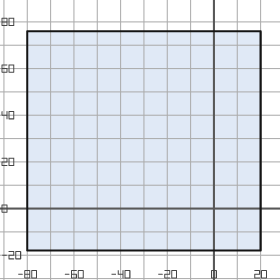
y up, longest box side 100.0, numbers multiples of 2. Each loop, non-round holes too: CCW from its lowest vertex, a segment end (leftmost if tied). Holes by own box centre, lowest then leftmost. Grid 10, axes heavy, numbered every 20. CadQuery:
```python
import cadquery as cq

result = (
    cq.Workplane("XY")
    .moveTo(-80.0, -18.0)
    .lineTo(20.0, -18.0)
    .lineTo(20.0, 76.0)
    .lineTo(-80.0, 76.0)
    .close()
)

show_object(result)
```